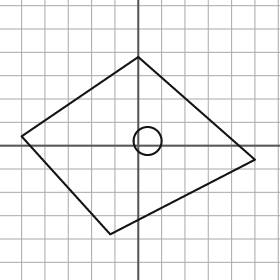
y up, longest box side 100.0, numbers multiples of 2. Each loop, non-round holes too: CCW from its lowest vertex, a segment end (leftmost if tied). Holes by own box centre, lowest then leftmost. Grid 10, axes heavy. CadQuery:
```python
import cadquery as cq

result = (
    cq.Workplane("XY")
    .moveTo(-12.0, -38.0)
    .lineTo(50.0, -6.0)
    .lineTo(0.0, 38.0)
    .lineTo(-50.0, 4.0)
    .close()
    .moveTo(4.0, 2.0)
    .circle(6.0)
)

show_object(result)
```